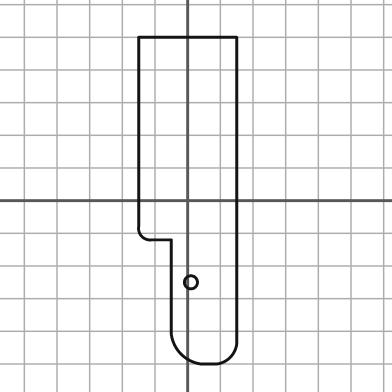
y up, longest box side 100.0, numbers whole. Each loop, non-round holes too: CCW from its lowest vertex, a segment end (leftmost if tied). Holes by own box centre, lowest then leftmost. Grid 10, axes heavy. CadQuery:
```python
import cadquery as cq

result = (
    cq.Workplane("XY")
    .moveTo(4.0, -50.0)
    .lineTo(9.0, -50.0)
    .threePointArc((13.0, -48.0), (15.0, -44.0))
    .lineTo(15.0, 50.0)
    .lineTo(-15.0, 50.0)
    .lineTo(-15.0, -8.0)
    .threePointArc((-14.0, -11.0), (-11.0, -12.0))
    .lineTo(-5.0, -12.0)
    .lineTo(-5.0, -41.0)
    .threePointArc((-2.0, -47.0), (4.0, -50.0))
    .close()
    .moveTo(1.0, -25.0)
    .circle(2.0)
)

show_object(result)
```